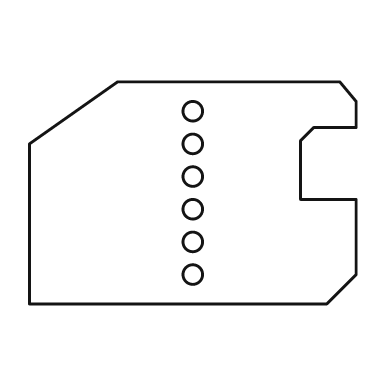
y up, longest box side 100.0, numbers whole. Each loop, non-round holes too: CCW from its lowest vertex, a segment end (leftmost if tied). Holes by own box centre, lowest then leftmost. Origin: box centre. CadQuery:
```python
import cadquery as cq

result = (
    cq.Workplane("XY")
    .moveTo(-50.0, -34.0)
    .lineTo(41.0, -34.0)
    .lineTo(50.0, -25.0)
    .lineTo(50.0, -2.0)
    .lineTo(33.0, -2.0)
    .lineTo(33.0, 16.0)
    .lineTo(37.0, 20.0)
    .lineTo(50.0, 20.0)
    .lineTo(50.0, 28.0)
    .lineTo(45.0, 34.0)
    .lineTo(-23.0, 34.0)
    .lineTo(-50.0, 15.0)
    .close()
    .moveTo(0.0, -25.0)
    .circle(3.0)
    .moveTo(0.0, -15.0)
    .circle(3.0)
    .moveTo(0.0, -5.0)
    .circle(3.0)
    .moveTo(0.0, 5.0)
    .circle(3.0)
    .moveTo(0.0, 15.0)
    .circle(3.0)
    .moveTo(0.0, 25.0)
    .circle(3.0)
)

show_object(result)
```